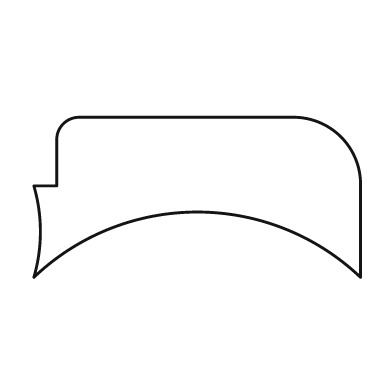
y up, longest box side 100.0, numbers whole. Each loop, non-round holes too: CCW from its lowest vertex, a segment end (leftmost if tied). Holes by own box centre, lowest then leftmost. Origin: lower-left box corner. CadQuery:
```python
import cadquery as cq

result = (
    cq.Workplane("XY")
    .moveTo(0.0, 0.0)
    .threePointArc((50.0, 20.0), (100.0, 0.0))
    .lineTo(100.0, 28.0)
    .threePointArc((94.0, 43.0), (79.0, 49.0))
    .lineTo(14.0, 49.0)
    .threePointArc((9.0, 47.0), (7.0, 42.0))
    .lineTo(7.0, 28.0)
    .lineTo(0.0, 28.0)
    .threePointArc((2.0, 14.0), (0.0, 0.0))
    .close()
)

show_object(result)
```